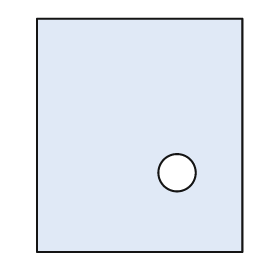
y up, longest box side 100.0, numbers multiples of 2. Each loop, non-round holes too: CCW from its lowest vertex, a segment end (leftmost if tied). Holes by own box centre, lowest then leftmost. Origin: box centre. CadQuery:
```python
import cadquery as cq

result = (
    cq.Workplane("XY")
    .moveTo(-44.0, -50.0)
    .lineTo(44.0, -50.0)
    .lineTo(44.0, 50.0)
    .lineTo(-44.0, 50.0)
    .close()
    .moveTo(16.0, -16.0)
    .circle(8.0)
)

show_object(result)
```